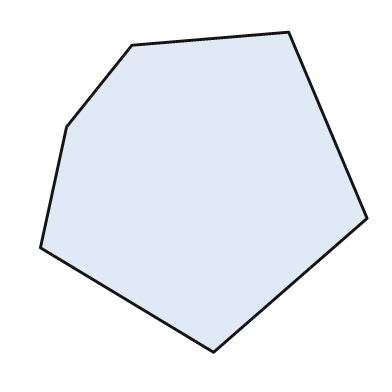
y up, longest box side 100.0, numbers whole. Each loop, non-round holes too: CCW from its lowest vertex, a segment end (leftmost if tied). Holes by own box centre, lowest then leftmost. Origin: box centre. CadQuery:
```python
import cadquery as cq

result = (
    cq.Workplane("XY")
    .moveTo(3.0, -49.0)
    .lineTo(50.0, -8.0)
    .lineTo(26.0, 49.0)
    .lineTo(-22.0, 45.0)
    .lineTo(-42.0, 20.0)
    .lineTo(-50.0, -17.0)
    .close()
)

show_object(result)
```